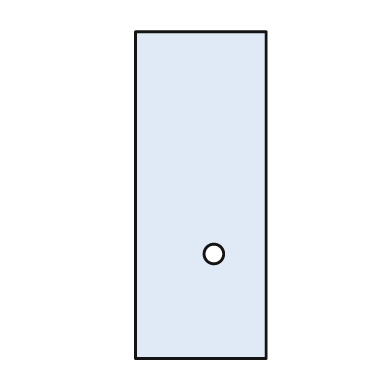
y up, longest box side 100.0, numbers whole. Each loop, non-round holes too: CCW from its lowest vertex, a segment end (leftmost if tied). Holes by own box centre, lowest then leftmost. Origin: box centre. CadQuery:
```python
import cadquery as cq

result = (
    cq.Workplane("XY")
    .moveTo(-20.0, -50.0)
    .lineTo(20.0, -50.0)
    .lineTo(20.0, 50.0)
    .lineTo(-20.0, 50.0)
    .close()
    .moveTo(4.0, -18.0)
    .circle(3.0)
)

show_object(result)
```